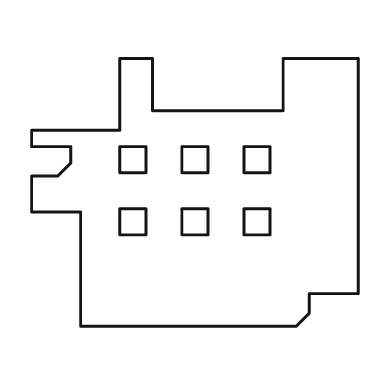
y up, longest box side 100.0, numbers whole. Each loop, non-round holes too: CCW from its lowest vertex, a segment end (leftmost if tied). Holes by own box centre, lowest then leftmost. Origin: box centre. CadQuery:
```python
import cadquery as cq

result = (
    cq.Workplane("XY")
    .moveTo(-35.0, -41.0)
    .lineTo(31.0, -41.0)
    .lineTo(35.0, -37.0)
    .lineTo(35.0, -31.0)
    .lineTo(50.0, -31.0)
    .lineTo(50.0, 41.0)
    .lineTo(27.0, 41.0)
    .lineTo(27.0, 25.0)
    .lineTo(-13.0, 25.0)
    .lineTo(-13.0, 41.0)
    .lineTo(-23.0, 41.0)
    .lineTo(-23.0, 19.0)
    .lineTo(-50.0, 19.0)
    .lineTo(-50.0, 14.0)
    .lineTo(-38.0, 14.0)
    .lineTo(-38.0, 9.0)
    .lineTo(-42.0, 5.0)
    .lineTo(-50.0, 5.0)
    .lineTo(-50.0, -6.0)
    .lineTo(-35.0, -6.0)
    .close()
    .moveTo(-23.0, -13.0)
    .lineTo(-15.0, -13.0)
    .lineTo(-15.0, -5.0)
    .lineTo(-23.0, -5.0)
    .close()
    .moveTo(-4.0, -13.0)
    .lineTo(4.0, -13.0)
    .lineTo(4.0, -5.0)
    .lineTo(-4.0, -5.0)
    .close()
    .moveTo(15.0, -13.0)
    .lineTo(23.0, -13.0)
    .lineTo(23.0, -5.0)
    .lineTo(15.0, -5.0)
    .close()
    .moveTo(-23.0, 6.0)
    .lineTo(-15.0, 6.0)
    .lineTo(-15.0, 14.0)
    .lineTo(-23.0, 14.0)
    .close()
    .moveTo(-4.0, 6.0)
    .lineTo(4.0, 6.0)
    .lineTo(4.0, 14.0)
    .lineTo(-4.0, 14.0)
    .close()
    .moveTo(15.0, 6.0)
    .lineTo(23.0, 6.0)
    .lineTo(23.0, 14.0)
    .lineTo(15.0, 14.0)
    .close()
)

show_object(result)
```